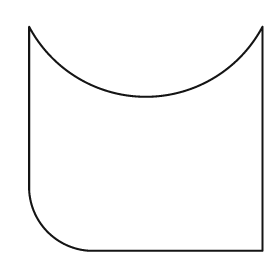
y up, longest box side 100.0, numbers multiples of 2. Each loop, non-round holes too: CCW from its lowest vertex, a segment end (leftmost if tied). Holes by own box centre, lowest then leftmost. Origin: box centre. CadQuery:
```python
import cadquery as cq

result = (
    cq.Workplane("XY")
    .moveTo(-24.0, -48.0)
    .lineTo(50.0, -48.0)
    .lineTo(50.0, 48.0)
    .threePointArc((0.0, 18.0), (-50.0, 48.0))
    .lineTo(-50.0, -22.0)
    .threePointArc((-42.0, -40.0), (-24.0, -48.0))
    .close()
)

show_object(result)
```